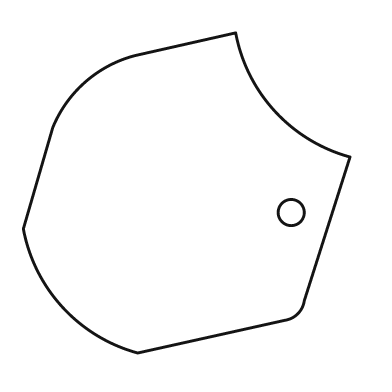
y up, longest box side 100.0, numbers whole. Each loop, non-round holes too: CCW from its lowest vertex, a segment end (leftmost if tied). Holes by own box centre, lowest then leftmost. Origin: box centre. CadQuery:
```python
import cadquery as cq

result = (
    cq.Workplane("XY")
    .moveTo(-15.0, -49.0)
    .lineTo(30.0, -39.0)
    .threePointArc((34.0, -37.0), (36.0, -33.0))
    .lineTo(50.0, 11.0)
    .threePointArc((27.0, 25.0), (15.0, 49.0))
    .lineTo(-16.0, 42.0)
    .threePointArc((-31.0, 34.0), (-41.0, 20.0))
    .lineTo(-50.0, -11.0)
    .threePointArc((-38.0, -35.0), (-15.0, -49.0))
    .close()
    .moveTo(32.0, -6.0)
    .circle(4.0)
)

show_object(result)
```